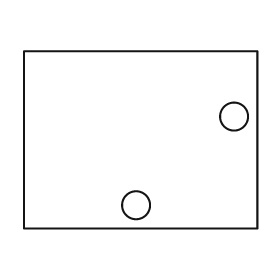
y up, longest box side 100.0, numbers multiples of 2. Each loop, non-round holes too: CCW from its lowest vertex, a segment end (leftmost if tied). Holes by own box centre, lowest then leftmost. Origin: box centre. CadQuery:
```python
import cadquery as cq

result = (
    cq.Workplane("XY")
    .moveTo(-50.0, -38.0)
    .lineTo(50.0, -38.0)
    .lineTo(50.0, 38.0)
    .lineTo(-50.0, 38.0)
    .close()
    .moveTo(-2.0, -28.0)
    .circle(6.0)
    .moveTo(40.0, 10.0)
    .circle(6.0)
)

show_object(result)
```